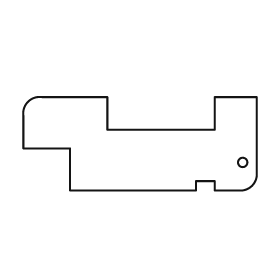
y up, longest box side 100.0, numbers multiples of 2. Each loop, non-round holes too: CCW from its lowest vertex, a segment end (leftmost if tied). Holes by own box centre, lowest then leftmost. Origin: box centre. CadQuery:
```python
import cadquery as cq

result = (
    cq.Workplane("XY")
    .moveTo(-30.0, -20.0)
    .lineTo(24.0, -20.0)
    .lineTo(24.0, -16.0)
    .lineTo(32.0, -16.0)
    .lineTo(32.0, -20.0)
    .lineTo(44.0, -20.0)
    .threePointArc((48.0, -18.0), (50.0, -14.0))
    .lineTo(50.0, 20.0)
    .lineTo(32.0, 20.0)
    .lineTo(32.0, 6.0)
    .lineTo(-14.0, 6.0)
    .lineTo(-14.0, 20.0)
    .lineTo(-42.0, 20.0)
    .threePointArc((-48.0, 18.0), (-50.0, 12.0))
    .lineTo(-50.0, -2.0)
    .lineTo(-30.0, -2.0)
    .close()
    .moveTo(44.0, -8.0)
    .circle(2.0)
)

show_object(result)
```